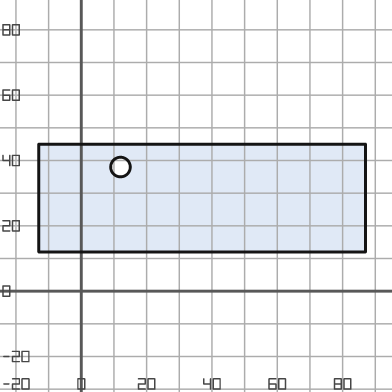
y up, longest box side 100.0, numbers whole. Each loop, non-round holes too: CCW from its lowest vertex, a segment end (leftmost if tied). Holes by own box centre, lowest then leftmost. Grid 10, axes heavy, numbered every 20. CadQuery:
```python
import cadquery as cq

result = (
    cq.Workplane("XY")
    .moveTo(-13.0, 12.0)
    .lineTo(87.0, 12.0)
    .lineTo(87.0, 45.0)
    .lineTo(-13.0, 45.0)
    .close()
    .moveTo(12.0, 38.0)
    .circle(3.0)
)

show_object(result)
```